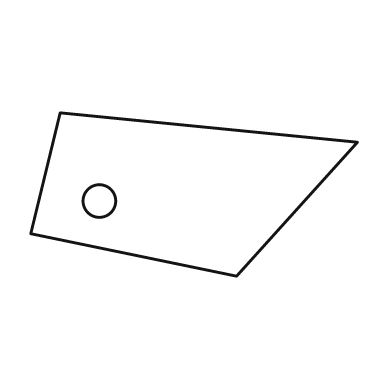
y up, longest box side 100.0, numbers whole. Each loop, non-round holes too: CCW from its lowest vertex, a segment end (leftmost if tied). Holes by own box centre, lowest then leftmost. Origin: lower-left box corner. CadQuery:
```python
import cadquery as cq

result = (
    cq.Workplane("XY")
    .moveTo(63.0, 0.0)
    .lineTo(100.0, 41.0)
    .lineTo(9.0, 50.0)
    .lineTo(0.0, 13.0)
    .close()
    .moveTo(21.0, 23.0)
    .circle(5.0)
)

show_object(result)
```